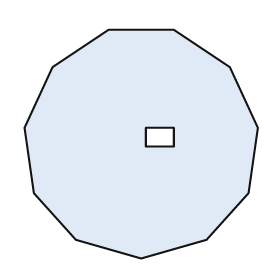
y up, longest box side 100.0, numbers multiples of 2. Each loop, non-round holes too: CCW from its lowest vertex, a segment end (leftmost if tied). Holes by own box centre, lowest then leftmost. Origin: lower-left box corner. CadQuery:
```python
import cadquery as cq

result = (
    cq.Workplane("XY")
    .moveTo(50.0, 0.0)
    .lineTo(78.0, 8.0)
    .lineTo(96.0, 28.0)
    .lineTo(100.0, 56.0)
    .lineTo(88.0, 82.0)
    .lineTo(64.0, 98.0)
    .lineTo(36.0, 98.0)
    .lineTo(12.0, 82.0)
    .lineTo(0.0, 56.0)
    .lineTo(4.0, 28.0)
    .lineTo(22.0, 8.0)
    .close()
    .moveTo(52.0, 48.0)
    .lineTo(64.0, 48.0)
    .lineTo(64.0, 56.0)
    .lineTo(52.0, 56.0)
    .close()
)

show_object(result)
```